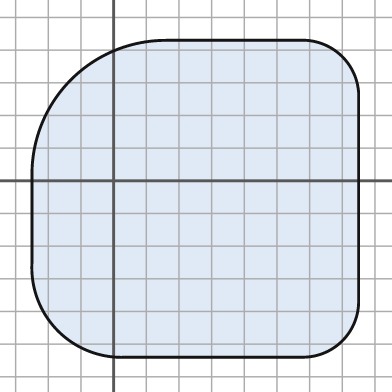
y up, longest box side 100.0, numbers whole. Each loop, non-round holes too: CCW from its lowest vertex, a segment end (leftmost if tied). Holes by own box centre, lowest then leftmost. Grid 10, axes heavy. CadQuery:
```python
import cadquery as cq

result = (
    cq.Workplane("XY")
    .moveTo(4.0, -54.0)
    .lineTo(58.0, -54.0)
    .threePointArc((70.0, -49.0), (75.0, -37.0))
    .lineTo(75.0, 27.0)
    .threePointArc((70.0, 38.0), (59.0, 43.0))
    .lineTo(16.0, 43.0)
    .threePointArc((-13.0, 31.0), (-25.0, 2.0))
    .lineTo(-25.0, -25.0)
    .threePointArc((-17.0, -46.0), (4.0, -54.0))
    .close()
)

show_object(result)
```